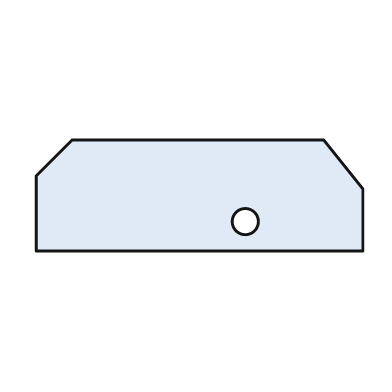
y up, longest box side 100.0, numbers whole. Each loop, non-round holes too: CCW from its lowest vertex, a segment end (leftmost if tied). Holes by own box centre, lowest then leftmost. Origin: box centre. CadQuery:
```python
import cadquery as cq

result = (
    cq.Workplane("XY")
    .moveTo(-50.0, -17.0)
    .lineTo(50.0, -17.0)
    .lineTo(50.0, 2.0)
    .lineTo(38.0, 17.0)
    .lineTo(-39.0, 17.0)
    .lineTo(-50.0, 6.0)
    .close()
    .moveTo(14.0, -8.0)
    .circle(4.0)
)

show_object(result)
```